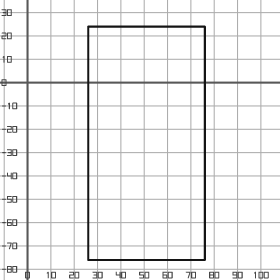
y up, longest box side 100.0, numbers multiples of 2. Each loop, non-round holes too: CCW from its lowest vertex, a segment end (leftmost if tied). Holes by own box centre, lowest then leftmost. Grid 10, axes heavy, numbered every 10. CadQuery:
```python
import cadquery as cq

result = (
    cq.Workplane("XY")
    .moveTo(26.0, -76.0)
    .lineTo(76.0, -76.0)
    .lineTo(76.0, 24.0)
    .lineTo(26.0, 24.0)
    .close()
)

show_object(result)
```